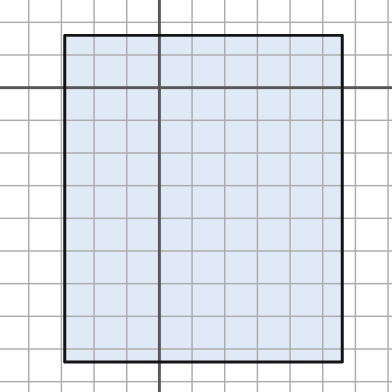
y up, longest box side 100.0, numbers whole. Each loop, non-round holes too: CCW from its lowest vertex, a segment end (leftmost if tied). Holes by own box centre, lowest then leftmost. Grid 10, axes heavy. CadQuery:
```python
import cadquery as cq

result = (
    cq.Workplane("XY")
    .moveTo(-29.0, -84.0)
    .lineTo(56.0, -84.0)
    .lineTo(56.0, 16.0)
    .lineTo(-29.0, 16.0)
    .close()
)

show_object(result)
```